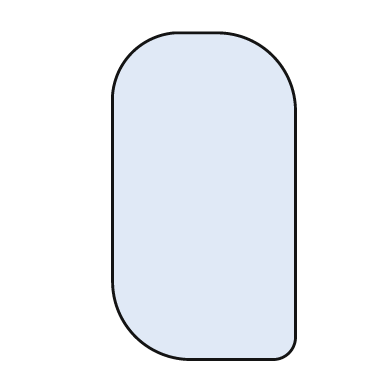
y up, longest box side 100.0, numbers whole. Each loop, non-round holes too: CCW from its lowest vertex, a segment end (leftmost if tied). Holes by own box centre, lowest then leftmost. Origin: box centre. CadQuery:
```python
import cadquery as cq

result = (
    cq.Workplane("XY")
    .moveTo(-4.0, -50.0)
    .lineTo(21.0, -50.0)
    .threePointArc((26.0, -48.0), (28.0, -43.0))
    .lineTo(28.0, 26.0)
    .threePointArc((21.0, 43.0), (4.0, 50.0))
    .lineTo(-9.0, 50.0)
    .threePointArc((-22.0, 44.0), (-28.0, 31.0))
    .lineTo(-28.0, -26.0)
    .threePointArc((-21.0, -43.0), (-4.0, -50.0))
    .close()
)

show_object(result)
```